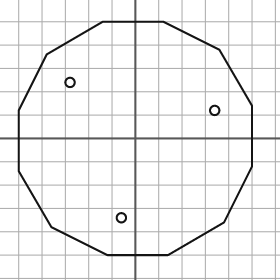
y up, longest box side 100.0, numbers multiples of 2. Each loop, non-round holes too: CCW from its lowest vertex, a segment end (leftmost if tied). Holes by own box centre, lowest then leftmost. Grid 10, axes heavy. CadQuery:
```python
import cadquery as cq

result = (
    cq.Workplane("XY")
    .moveTo(-12.0, -50.0)
    .lineTo(14.0, -50.0)
    .lineTo(38.0, -36.0)
    .lineTo(50.0, -12.0)
    .lineTo(50.0, 14.0)
    .lineTo(36.0, 38.0)
    .lineTo(12.0, 50.0)
    .lineTo(-14.0, 50.0)
    .lineTo(-38.0, 36.0)
    .lineTo(-50.0, 12.0)
    .lineTo(-50.0, -14.0)
    .lineTo(-36.0, -38.0)
    .close()
    .moveTo(-6.0, -34.0)
    .circle(2.0)
    .moveTo(34.0, 12.0)
    .circle(2.0)
    .moveTo(-28.0, 24.0)
    .circle(2.0)
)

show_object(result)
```